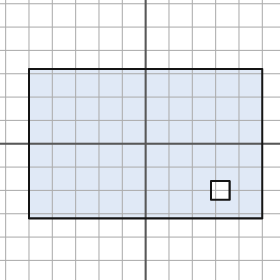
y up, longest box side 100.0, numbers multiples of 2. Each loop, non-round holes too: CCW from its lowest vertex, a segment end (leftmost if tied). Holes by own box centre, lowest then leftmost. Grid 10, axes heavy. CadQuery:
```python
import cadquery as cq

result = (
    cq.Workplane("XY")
    .moveTo(-50.0, -32.0)
    .lineTo(50.0, -32.0)
    .lineTo(50.0, 32.0)
    .lineTo(-50.0, 32.0)
    .close()
    .moveTo(28.0, -24.0)
    .lineTo(36.0, -24.0)
    .lineTo(36.0, -16.0)
    .lineTo(28.0, -16.0)
    .close()
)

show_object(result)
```